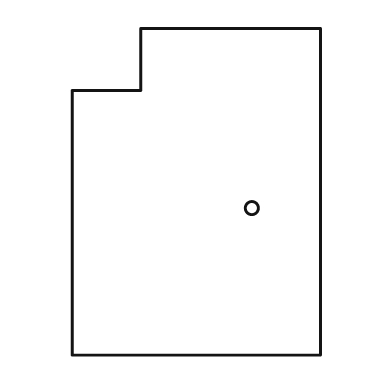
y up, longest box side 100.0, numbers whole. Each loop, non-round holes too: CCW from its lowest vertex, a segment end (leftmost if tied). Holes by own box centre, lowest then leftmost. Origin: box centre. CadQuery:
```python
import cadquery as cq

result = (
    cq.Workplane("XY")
    .moveTo(-38.0, -50.0)
    .lineTo(38.0, -50.0)
    .lineTo(38.0, 50.0)
    .lineTo(-17.0, 50.0)
    .lineTo(-17.0, 31.0)
    .lineTo(-38.0, 31.0)
    .close()
    .moveTo(17.0, -5.0)
    .circle(2.0)
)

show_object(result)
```